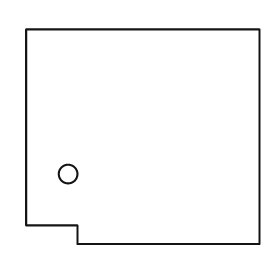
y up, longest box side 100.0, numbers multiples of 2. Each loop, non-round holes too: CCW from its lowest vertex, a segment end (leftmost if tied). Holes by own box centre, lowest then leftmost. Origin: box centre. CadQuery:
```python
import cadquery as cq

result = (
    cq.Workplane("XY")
    .moveTo(-28.0, -46.0)
    .lineTo(50.0, -46.0)
    .lineTo(50.0, 46.0)
    .lineTo(-50.0, 46.0)
    .lineTo(-50.0, -38.0)
    .lineTo(-28.0, -38.0)
    .close()
    .moveTo(-32.0, -16.0)
    .circle(4.0)
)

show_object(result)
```